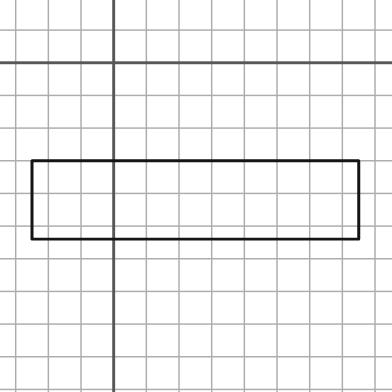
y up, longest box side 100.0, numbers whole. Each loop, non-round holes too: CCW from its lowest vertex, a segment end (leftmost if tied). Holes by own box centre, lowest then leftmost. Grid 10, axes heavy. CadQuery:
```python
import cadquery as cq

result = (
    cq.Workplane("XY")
    .moveTo(-25.0, -54.0)
    .lineTo(75.0, -54.0)
    .lineTo(75.0, -30.0)
    .lineTo(-25.0, -30.0)
    .close()
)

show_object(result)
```